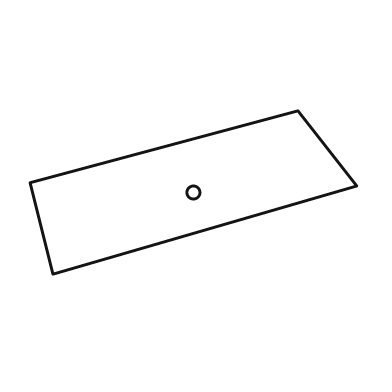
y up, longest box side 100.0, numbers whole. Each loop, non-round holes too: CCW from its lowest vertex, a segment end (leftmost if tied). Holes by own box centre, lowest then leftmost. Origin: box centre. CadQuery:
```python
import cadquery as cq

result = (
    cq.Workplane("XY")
    .moveTo(-43.0, -25.0)
    .lineTo(50.0, 2.0)
    .lineTo(32.0, 25.0)
    .lineTo(-50.0, 3.0)
    .close()
    .moveTo(0.0, 0.0)
    .circle(2.0)
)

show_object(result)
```